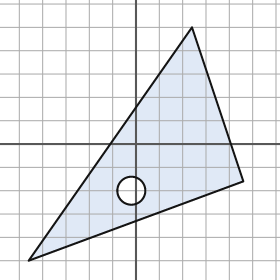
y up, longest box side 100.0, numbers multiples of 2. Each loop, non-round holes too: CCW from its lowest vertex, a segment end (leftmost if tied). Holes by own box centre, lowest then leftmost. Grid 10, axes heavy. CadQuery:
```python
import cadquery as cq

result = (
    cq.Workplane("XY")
    .moveTo(-46.0, -50.0)
    .lineTo(46.0, -16.0)
    .lineTo(24.0, 50.0)
    .close()
    .moveTo(-2.0, -20.0)
    .circle(6.0)
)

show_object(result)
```